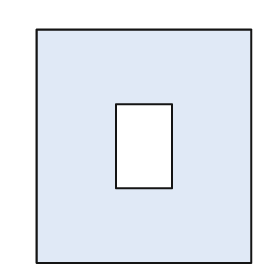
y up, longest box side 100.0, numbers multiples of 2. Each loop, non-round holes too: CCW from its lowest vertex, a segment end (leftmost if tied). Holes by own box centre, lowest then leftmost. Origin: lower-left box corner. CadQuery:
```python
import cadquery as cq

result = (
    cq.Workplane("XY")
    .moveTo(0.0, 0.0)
    .lineTo(92.0, 0.0)
    .lineTo(92.0, 100.0)
    .lineTo(0.0, 100.0)
    .close()
    .moveTo(34.0, 32.0)
    .lineTo(58.0, 32.0)
    .lineTo(58.0, 68.0)
    .lineTo(34.0, 68.0)
    .close()
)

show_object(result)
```